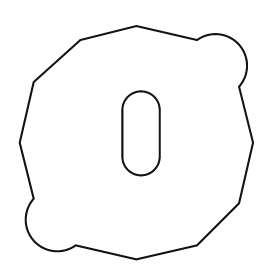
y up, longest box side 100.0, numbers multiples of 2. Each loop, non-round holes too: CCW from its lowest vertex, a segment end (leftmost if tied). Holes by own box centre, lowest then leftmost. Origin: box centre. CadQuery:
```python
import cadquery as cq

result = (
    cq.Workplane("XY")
    .moveTo(0.0, -50.0)
    .lineTo(26.0, -44.0)
    .lineTo(44.0, -26.0)
    .lineTo(50.0, 0.0)
    .lineTo(44.0, 24.0)
    .threePointArc((44.0, 42.0), (26.0, 44.0))
    .lineTo(0.0, 50.0)
    .lineTo(-24.0, 44.0)
    .lineTo(-44.0, 26.0)
    .lineTo(-50.0, 0.0)
    .lineTo(-44.0, -24.0)
    .threePointArc((-44.0, -42.0), (-26.0, -44.0))
    .close()
    .moveTo(-6.0, -6.0)
    .threePointArc((2.0, -14.0), (10.0, -6.0))
    .lineTo(10.0, 14.0)
    .threePointArc((2.0, 22.0), (-6.0, 14.0))
    .close()
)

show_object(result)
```